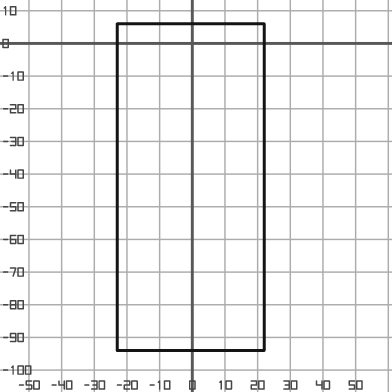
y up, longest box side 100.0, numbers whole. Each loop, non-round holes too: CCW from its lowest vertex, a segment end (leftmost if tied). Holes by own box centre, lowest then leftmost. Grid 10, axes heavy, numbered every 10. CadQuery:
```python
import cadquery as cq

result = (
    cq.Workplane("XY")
    .moveTo(-23.0, -94.0)
    .lineTo(22.0, -94.0)
    .lineTo(22.0, 6.0)
    .lineTo(-23.0, 6.0)
    .close()
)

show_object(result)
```